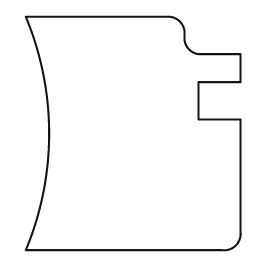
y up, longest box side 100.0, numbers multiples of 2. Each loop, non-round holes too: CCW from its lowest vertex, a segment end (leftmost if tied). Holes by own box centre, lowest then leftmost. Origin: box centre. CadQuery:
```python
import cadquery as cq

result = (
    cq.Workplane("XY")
    .moveTo(-46.0, -50.0)
    .lineTo(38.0, -50.0)
    .threePointArc((44.0, -48.0), (46.0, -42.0))
    .lineTo(46.0, 6.0)
    .lineTo(28.0, 6.0)
    .lineTo(28.0, 22.0)
    .lineTo(46.0, 22.0)
    .lineTo(46.0, 34.0)
    .lineTo(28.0, 34.0)
    .threePointArc((24.0, 36.0), (22.0, 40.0))
    .lineTo(22.0, 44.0)
    .threePointArc((20.0, 48.0), (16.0, 50.0))
    .lineTo(-46.0, 50.0)
    .threePointArc((-36.0, 0.0), (-46.0, -50.0))
    .close()
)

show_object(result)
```